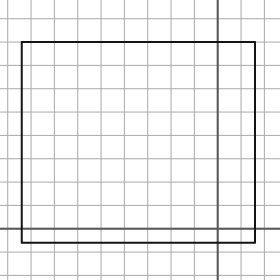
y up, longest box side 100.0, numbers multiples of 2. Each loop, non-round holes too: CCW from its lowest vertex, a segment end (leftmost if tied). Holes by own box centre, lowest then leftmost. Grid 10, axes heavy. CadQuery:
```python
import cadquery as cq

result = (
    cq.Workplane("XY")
    .moveTo(-84.0, -6.0)
    .lineTo(16.0, -6.0)
    .lineTo(16.0, 80.0)
    .lineTo(-84.0, 80.0)
    .close()
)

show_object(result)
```